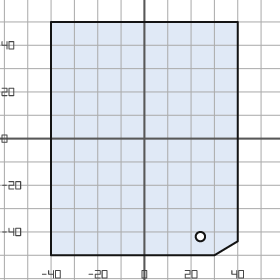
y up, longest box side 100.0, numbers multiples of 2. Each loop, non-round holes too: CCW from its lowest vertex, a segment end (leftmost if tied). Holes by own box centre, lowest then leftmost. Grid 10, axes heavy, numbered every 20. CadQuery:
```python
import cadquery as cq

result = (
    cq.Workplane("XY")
    .moveTo(-40.0, -50.0)
    .lineTo(30.0, -50.0)
    .lineTo(40.0, -44.0)
    .lineTo(40.0, 50.0)
    .lineTo(-40.0, 50.0)
    .close()
    .moveTo(24.0, -42.0)
    .circle(2.0)
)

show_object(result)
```